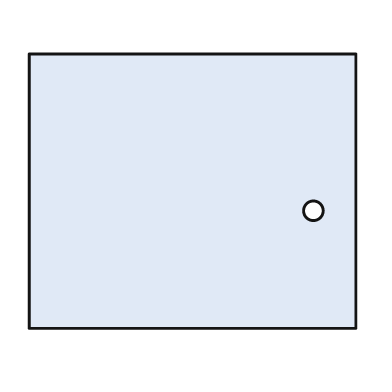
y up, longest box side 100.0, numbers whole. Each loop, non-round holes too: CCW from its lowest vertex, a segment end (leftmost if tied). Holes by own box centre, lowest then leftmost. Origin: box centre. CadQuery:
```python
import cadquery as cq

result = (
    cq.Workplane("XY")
    .moveTo(-50.0, -42.0)
    .lineTo(50.0, -42.0)
    .lineTo(50.0, 42.0)
    .lineTo(-50.0, 42.0)
    .close()
    .moveTo(37.0, -6.0)
    .circle(3.0)
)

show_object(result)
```